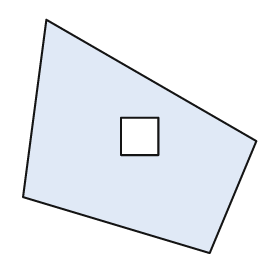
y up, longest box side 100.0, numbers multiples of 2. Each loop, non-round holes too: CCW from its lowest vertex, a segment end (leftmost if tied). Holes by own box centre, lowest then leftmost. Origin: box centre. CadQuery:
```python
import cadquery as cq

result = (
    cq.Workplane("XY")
    .moveTo(30.0, -50.0)
    .lineTo(50.0, -2.0)
    .lineTo(-40.0, 50.0)
    .lineTo(-50.0, -26.0)
    .close()
    .moveTo(-8.0, -8.0)
    .lineTo(8.0, -8.0)
    .lineTo(8.0, 8.0)
    .lineTo(-8.0, 8.0)
    .close()
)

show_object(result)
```